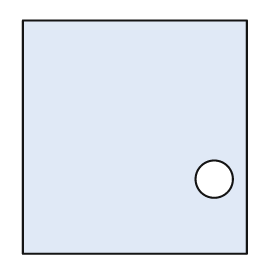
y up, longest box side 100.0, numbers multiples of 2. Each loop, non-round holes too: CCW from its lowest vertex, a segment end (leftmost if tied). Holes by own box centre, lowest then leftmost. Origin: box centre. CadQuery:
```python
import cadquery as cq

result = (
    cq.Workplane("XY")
    .moveTo(-48.0, -50.0)
    .lineTo(48.0, -50.0)
    .lineTo(48.0, 50.0)
    .lineTo(-48.0, 50.0)
    .close()
    .moveTo(34.0, -18.0)
    .circle(8.0)
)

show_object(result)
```